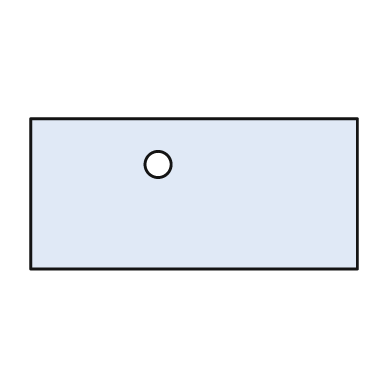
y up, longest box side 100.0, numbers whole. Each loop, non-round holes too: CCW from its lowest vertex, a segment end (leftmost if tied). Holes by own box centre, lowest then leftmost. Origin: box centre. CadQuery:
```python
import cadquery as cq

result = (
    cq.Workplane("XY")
    .moveTo(-50.0, -23.0)
    .lineTo(50.0, -23.0)
    .lineTo(50.0, 23.0)
    .lineTo(-50.0, 23.0)
    .close()
    .moveTo(-11.0, 9.0)
    .circle(4.0)
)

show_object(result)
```